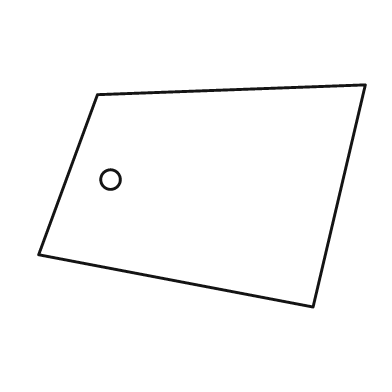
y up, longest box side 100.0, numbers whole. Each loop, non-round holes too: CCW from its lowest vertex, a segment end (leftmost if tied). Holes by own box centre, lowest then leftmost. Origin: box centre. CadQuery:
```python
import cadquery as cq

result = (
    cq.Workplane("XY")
    .moveTo(34.0, -34.0)
    .lineTo(50.0, 34.0)
    .lineTo(-32.0, 31.0)
    .lineTo(-50.0, -18.0)
    .close()
    .moveTo(-28.0, 5.0)
    .circle(3.0)
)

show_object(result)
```